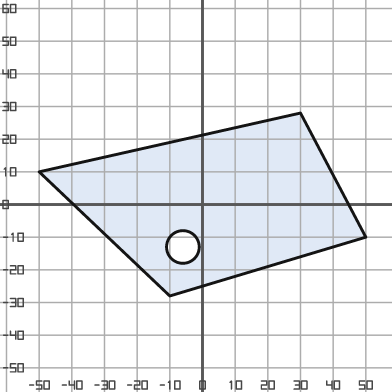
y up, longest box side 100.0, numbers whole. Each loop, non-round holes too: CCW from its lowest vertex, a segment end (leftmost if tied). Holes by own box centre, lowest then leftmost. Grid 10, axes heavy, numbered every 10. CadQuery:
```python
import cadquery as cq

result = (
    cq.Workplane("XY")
    .moveTo(-10.0, -28.0)
    .lineTo(50.0, -10.0)
    .lineTo(30.0, 28.0)
    .lineTo(-50.0, 10.0)
    .close()
    .moveTo(-6.0, -13.0)
    .circle(5.0)
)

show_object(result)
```